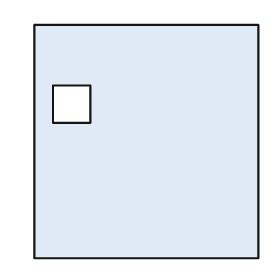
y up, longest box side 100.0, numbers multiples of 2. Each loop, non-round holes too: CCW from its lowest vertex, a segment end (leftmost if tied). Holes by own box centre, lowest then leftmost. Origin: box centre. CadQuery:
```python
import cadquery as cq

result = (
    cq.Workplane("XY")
    .moveTo(-48.0, -50.0)
    .lineTo(48.0, -50.0)
    .lineTo(48.0, 50.0)
    .lineTo(-48.0, 50.0)
    .close()
    .moveTo(-40.0, 8.0)
    .lineTo(-24.0, 8.0)
    .lineTo(-24.0, 24.0)
    .lineTo(-40.0, 24.0)
    .close()
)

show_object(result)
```